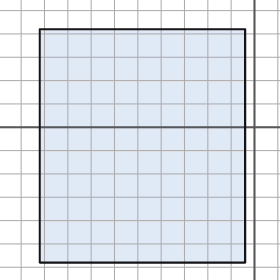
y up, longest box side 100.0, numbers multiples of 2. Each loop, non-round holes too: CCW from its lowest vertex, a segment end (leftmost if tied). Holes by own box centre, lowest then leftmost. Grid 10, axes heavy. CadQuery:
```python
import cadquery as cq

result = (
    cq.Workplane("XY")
    .moveTo(-92.0, -58.0)
    .lineTo(-4.0, -58.0)
    .lineTo(-4.0, 42.0)
    .lineTo(-92.0, 42.0)
    .close()
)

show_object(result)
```